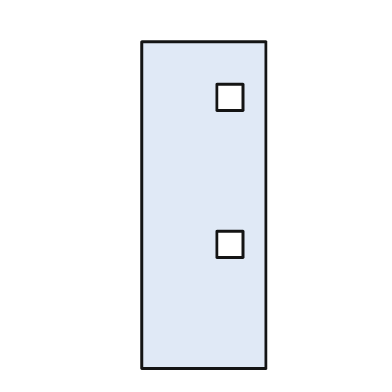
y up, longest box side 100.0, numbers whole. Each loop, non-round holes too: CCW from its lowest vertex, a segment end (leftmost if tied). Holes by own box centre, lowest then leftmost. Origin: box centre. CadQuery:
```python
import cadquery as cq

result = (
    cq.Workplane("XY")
    .moveTo(-19.0, -50.0)
    .lineTo(19.0, -50.0)
    .lineTo(19.0, 50.0)
    .lineTo(-19.0, 50.0)
    .close()
    .moveTo(4.0, -16.0)
    .lineTo(12.0, -16.0)
    .lineTo(12.0, -8.0)
    .lineTo(4.0, -8.0)
    .close()
    .moveTo(4.0, 29.0)
    .lineTo(12.0, 29.0)
    .lineTo(12.0, 37.0)
    .lineTo(4.0, 37.0)
    .close()
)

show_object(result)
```